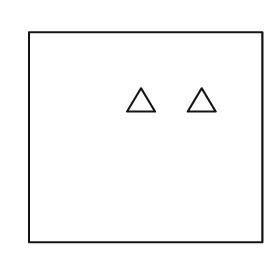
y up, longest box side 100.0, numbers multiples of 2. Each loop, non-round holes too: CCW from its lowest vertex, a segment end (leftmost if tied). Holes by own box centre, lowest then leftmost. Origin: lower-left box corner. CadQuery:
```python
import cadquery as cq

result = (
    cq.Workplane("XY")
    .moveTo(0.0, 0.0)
    .lineTo(100.0, 0.0)
    .lineTo(100.0, 90.0)
    .lineTo(0.0, 90.0)
    .close()
    .moveTo(42.0, 56.0)
    .lineTo(54.0, 56.0)
    .lineTo(48.0, 66.0)
    .close()
    .moveTo(68.0, 56.0)
    .lineTo(80.0, 56.0)
    .lineTo(74.0, 66.0)
    .close()
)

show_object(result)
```